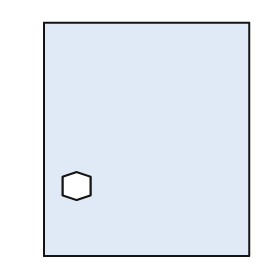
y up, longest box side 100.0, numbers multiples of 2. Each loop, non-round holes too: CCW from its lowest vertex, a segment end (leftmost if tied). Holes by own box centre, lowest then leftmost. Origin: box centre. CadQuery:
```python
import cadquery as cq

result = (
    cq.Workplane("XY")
    .moveTo(-44.0, -50.0)
    .lineTo(44.0, -50.0)
    .lineTo(44.0, 50.0)
    .lineTo(-44.0, 50.0)
    .close()
    .moveTo(-30.0, -26.0)
    .lineTo(-24.0, -24.0)
    .lineTo(-24.0, -16.0)
    .lineTo(-30.0, -14.0)
    .lineTo(-36.0, -16.0)
    .lineTo(-36.0, -24.0)
    .close()
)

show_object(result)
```